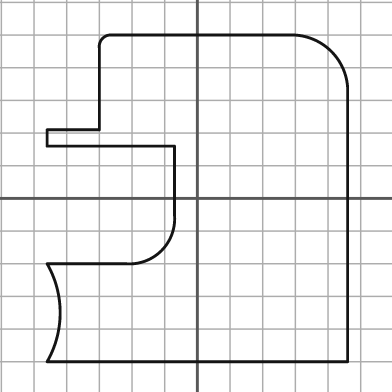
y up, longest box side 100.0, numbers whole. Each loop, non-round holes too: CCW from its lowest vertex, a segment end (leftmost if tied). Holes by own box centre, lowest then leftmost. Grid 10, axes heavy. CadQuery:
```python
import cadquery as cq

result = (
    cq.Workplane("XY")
    .moveTo(-46.0, -50.0)
    .lineTo(46.0, -50.0)
    .lineTo(46.0, 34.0)
    .threePointArc((41.0, 45.0), (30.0, 50.0))
    .lineTo(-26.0, 50.0)
    .threePointArc((-29.0, 49.0), (-30.0, 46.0))
    .lineTo(-30.0, 21.0)
    .lineTo(-46.0, 21.0)
    .lineTo(-46.0, 16.0)
    .lineTo(-7.0, 16.0)
    .lineTo(-7.0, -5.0)
    .threePointArc((-11.0, -16.0), (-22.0, -20.0))
    .lineTo(-46.0, -20.0)
    .threePointArc((-42.0, -35.0), (-46.0, -50.0))
    .close()
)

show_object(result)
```